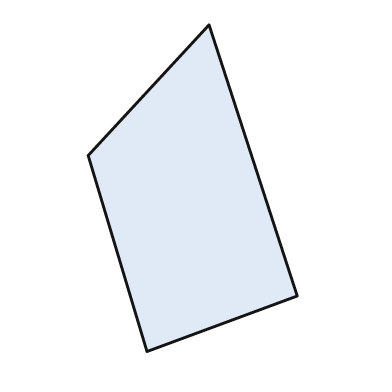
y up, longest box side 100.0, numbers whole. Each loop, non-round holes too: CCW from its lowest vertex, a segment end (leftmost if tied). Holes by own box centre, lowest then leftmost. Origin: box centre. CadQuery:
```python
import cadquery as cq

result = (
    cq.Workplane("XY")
    .moveTo(-14.0, -50.0)
    .lineTo(32.0, -33.0)
    .lineTo(5.0, 50.0)
    .lineTo(-32.0, 10.0)
    .close()
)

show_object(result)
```